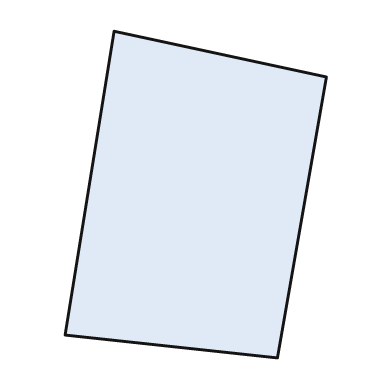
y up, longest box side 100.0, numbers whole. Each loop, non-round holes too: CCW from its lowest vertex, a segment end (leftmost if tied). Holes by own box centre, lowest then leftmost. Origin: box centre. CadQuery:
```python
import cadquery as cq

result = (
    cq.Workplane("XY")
    .moveTo(25.0, -50.0)
    .lineTo(40.0, 36.0)
    .lineTo(-25.0, 50.0)
    .lineTo(-40.0, -43.0)
    .close()
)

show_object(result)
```